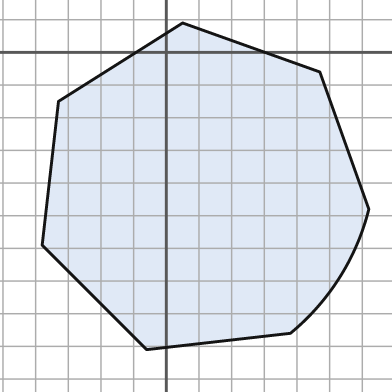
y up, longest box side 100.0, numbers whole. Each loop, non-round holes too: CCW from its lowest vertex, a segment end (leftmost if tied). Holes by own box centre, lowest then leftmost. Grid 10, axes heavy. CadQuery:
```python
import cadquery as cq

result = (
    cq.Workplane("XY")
    .moveTo(-6.0, -91.0)
    .lineTo(38.0, -86.0)
    .threePointArc((53.0, -69.0), (62.0, -48.0))
    .lineTo(47.0, -6.0)
    .lineTo(5.0, 9.0)
    .lineTo(-33.0, -15.0)
    .lineTo(-38.0, -59.0)
    .close()
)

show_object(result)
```